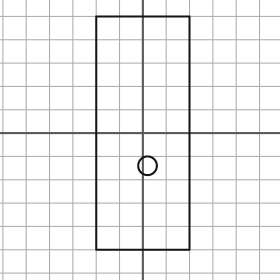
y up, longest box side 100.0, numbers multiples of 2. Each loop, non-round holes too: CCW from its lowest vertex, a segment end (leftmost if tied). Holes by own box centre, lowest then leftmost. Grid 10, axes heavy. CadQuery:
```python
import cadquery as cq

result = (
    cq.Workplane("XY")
    .moveTo(-20.0, -50.0)
    .lineTo(20.0, -50.0)
    .lineTo(20.0, 50.0)
    .lineTo(-20.0, 50.0)
    .close()
    .moveTo(2.0, -14.0)
    .circle(4.0)
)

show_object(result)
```